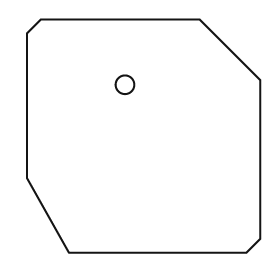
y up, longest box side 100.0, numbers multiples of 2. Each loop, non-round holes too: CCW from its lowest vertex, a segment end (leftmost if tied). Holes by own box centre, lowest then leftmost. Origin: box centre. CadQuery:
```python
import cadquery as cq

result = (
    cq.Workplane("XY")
    .moveTo(-32.0, -50.0)
    .lineTo(44.0, -50.0)
    .lineTo(50.0, -44.0)
    .lineTo(50.0, 24.0)
    .lineTo(24.0, 50.0)
    .lineTo(-44.0, 50.0)
    .lineTo(-50.0, 44.0)
    .lineTo(-50.0, -18.0)
    .close()
    .moveTo(-8.0, 22.0)
    .circle(4.0)
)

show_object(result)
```